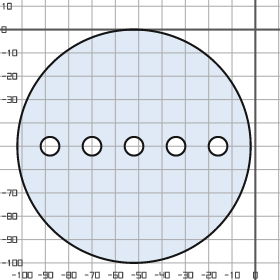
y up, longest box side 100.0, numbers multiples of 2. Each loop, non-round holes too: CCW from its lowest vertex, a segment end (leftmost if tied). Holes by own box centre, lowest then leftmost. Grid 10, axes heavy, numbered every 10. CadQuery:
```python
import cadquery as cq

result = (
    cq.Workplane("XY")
    .moveTo(-52.0, -50.0)
    .circle(50.0)
    .moveTo(-88.0, -50.0)
    .circle(4.0)
    .moveTo(-70.0, -50.0)
    .circle(4.0)
    .moveTo(-52.0, -50.0)
    .circle(4.0)
    .moveTo(-34.0, -50.0)
    .circle(4.0)
    .moveTo(-16.0, -50.0)
    .circle(4.0)
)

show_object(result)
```